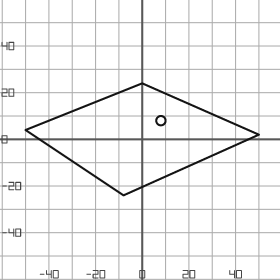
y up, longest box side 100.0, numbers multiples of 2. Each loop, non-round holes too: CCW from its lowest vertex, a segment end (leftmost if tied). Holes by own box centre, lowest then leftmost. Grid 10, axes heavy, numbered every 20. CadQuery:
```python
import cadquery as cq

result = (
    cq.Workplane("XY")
    .moveTo(-8.0, -24.0)
    .lineTo(50.0, 2.0)
    .lineTo(0.0, 24.0)
    .lineTo(-50.0, 4.0)
    .close()
    .moveTo(8.0, 8.0)
    .circle(2.0)
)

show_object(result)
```